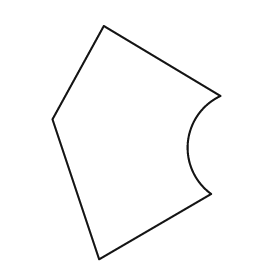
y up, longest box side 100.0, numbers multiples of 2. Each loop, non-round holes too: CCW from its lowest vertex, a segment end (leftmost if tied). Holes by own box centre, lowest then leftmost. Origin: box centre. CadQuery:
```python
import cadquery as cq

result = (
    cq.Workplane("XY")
    .moveTo(-16.0, -50.0)
    .lineTo(32.0, -22.0)
    .threePointArc((22.0, 0.0), (36.0, 20.0))
    .lineTo(-14.0, 50.0)
    .lineTo(-36.0, 10.0)
    .close()
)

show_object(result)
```